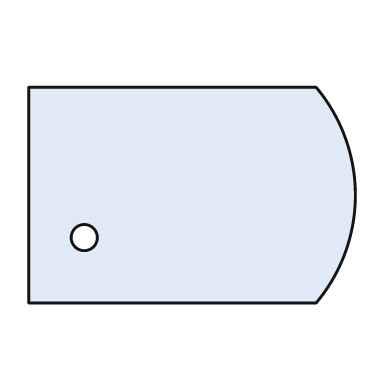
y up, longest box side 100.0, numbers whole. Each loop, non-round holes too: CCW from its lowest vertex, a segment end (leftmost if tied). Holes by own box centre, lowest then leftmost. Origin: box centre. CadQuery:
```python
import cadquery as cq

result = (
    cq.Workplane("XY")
    .moveTo(-50.0, -33.0)
    .lineTo(38.0, -33.0)
    .threePointArc((50.0, 0.0), (38.0, 33.0))
    .lineTo(-50.0, 33.0)
    .close()
    .moveTo(-33.0, -13.0)
    .circle(4.0)
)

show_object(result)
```